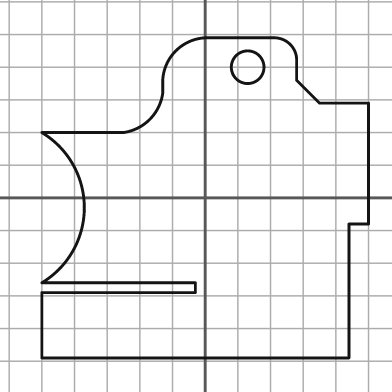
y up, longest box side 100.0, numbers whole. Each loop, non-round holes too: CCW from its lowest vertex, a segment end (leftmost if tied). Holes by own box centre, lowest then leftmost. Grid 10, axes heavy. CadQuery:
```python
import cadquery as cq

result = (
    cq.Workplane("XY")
    .moveTo(-50.0, -49.0)
    .lineTo(44.0, -49.0)
    .lineTo(44.0, -8.0)
    .lineTo(50.0, -8.0)
    .lineTo(50.0, 29.0)
    .lineTo(35.0, 29.0)
    .lineTo(28.0, 36.0)
    .lineTo(28.0, 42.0)
    .threePointArc((26.0, 47.0), (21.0, 49.0))
    .lineTo(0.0, 49.0)
    .threePointArc((-9.0, 45.0), (-13.0, 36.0))
    .lineTo(-13.0, 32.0)
    .threePointArc((-17.0, 24.0), (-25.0, 20.0))
    .lineTo(-50.0, 20.0)
    .threePointArc((-37.0, -3.0), (-50.0, -26.0))
    .lineTo(-3.0, -26.0)
    .lineTo(-3.0, -29.0)
    .lineTo(-50.0, -29.0)
    .close()
    .moveTo(13.0, 40.0)
    .circle(5.0)
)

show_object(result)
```